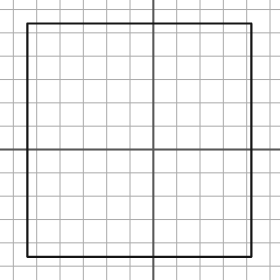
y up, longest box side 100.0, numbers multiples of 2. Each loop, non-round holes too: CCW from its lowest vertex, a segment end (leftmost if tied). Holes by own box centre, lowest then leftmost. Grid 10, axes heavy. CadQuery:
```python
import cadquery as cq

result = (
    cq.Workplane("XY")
    .moveTo(-54.0, -46.0)
    .lineTo(42.0, -46.0)
    .lineTo(42.0, 54.0)
    .lineTo(-54.0, 54.0)
    .close()
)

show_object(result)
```